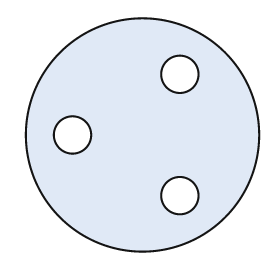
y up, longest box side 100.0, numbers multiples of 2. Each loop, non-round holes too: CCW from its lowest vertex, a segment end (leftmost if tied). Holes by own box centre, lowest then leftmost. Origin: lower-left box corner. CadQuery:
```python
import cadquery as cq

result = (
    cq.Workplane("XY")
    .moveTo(50.0, 50.0)
    .circle(50.0)
    .moveTo(66.0, 24.0)
    .circle(8.0)
    .moveTo(20.0, 50.0)
    .circle(8.0)
    .moveTo(66.0, 76.0)
    .circle(8.0)
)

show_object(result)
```